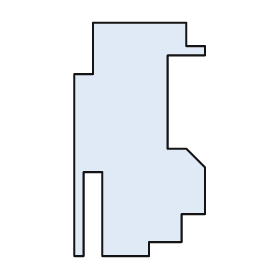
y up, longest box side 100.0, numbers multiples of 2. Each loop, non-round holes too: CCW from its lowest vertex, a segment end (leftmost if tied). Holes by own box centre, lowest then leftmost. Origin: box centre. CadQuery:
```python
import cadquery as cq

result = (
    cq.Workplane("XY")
    .moveTo(-28.0, -50.0)
    .lineTo(-24.0, -50.0)
    .lineTo(-24.0, -14.0)
    .lineTo(-16.0, -14.0)
    .lineTo(-16.0, -50.0)
    .lineTo(4.0, -50.0)
    .lineTo(4.0, -44.0)
    .lineTo(18.0, -44.0)
    .lineTo(18.0, -32.0)
    .lineTo(28.0, -32.0)
    .lineTo(28.0, -12.0)
    .lineTo(20.0, -4.0)
    .lineTo(12.0, -4.0)
    .lineTo(12.0, 36.0)
    .lineTo(28.0, 36.0)
    .lineTo(28.0, 40.0)
    .lineTo(20.0, 40.0)
    .lineTo(20.0, 50.0)
    .lineTo(-20.0, 50.0)
    .lineTo(-20.0, 28.0)
    .lineTo(-28.0, 28.0)
    .close()
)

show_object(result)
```